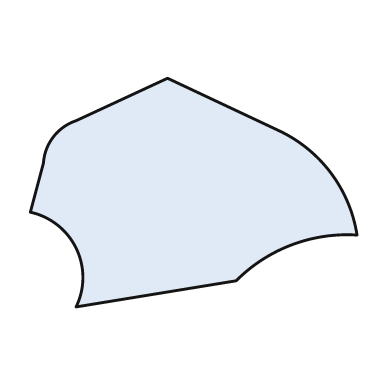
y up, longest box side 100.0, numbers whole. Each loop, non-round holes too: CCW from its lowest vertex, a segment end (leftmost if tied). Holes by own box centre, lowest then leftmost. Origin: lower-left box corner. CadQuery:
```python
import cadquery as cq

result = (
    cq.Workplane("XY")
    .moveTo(14.0, 0.0)
    .lineTo(63.0, 8.0)
    .threePointArc((80.0, 19.0), (100.0, 22.0))
    .threePointArc((92.0, 41.0), (76.0, 54.0))
    .lineTo(42.0, 70.0)
    .lineTo(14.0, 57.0)
    .threePointArc((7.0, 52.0), (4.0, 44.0))
    .lineTo(0.0, 29.0)
    .threePointArc((14.0, 18.0), (14.0, 0.0))
    .close()
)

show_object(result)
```